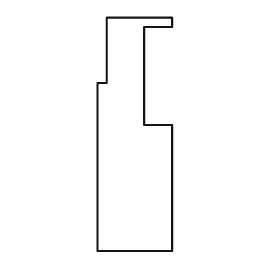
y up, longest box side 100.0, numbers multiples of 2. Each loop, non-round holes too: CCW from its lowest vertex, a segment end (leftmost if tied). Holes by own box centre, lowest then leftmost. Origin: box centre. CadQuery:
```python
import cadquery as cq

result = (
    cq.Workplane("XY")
    .moveTo(-16.0, -50.0)
    .lineTo(16.0, -50.0)
    .lineTo(16.0, 4.0)
    .lineTo(4.0, 4.0)
    .lineTo(4.0, 46.0)
    .lineTo(16.0, 46.0)
    .lineTo(16.0, 50.0)
    .lineTo(-12.0, 50.0)
    .lineTo(-12.0, 22.0)
    .lineTo(-16.0, 22.0)
    .close()
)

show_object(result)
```